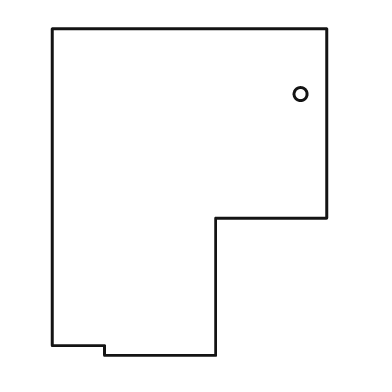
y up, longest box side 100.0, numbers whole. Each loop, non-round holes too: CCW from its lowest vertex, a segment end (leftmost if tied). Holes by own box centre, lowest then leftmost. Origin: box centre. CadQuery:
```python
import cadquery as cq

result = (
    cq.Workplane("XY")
    .moveTo(-26.0, -50.0)
    .lineTo(8.0, -50.0)
    .lineTo(8.0, -8.0)
    .lineTo(42.0, -8.0)
    .lineTo(42.0, 50.0)
    .lineTo(-42.0, 50.0)
    .lineTo(-42.0, -47.0)
    .lineTo(-26.0, -47.0)
    .close()
    .moveTo(34.0, 30.0)
    .circle(2.0)
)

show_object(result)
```